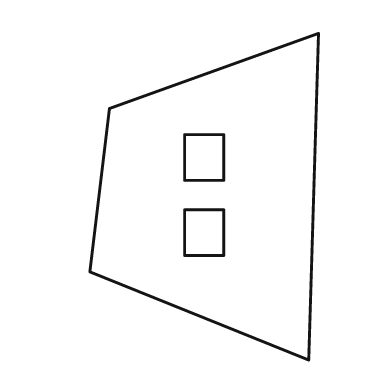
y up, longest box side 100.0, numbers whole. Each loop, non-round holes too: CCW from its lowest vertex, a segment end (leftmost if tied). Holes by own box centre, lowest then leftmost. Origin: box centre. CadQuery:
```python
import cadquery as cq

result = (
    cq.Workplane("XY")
    .moveTo(32.0, -50.0)
    .lineTo(35.0, 50.0)
    .lineTo(-29.0, 27.0)
    .lineTo(-35.0, -23.0)
    .close()
    .moveTo(-6.0, -18.0)
    .lineTo(6.0, -18.0)
    .lineTo(6.0, -4.0)
    .lineTo(-6.0, -4.0)
    .close()
    .moveTo(-6.0, 5.0)
    .lineTo(6.0, 5.0)
    .lineTo(6.0, 19.0)
    .lineTo(-6.0, 19.0)
    .close()
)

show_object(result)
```